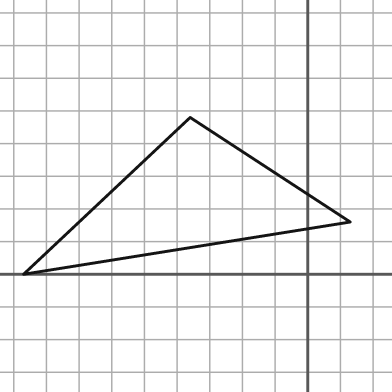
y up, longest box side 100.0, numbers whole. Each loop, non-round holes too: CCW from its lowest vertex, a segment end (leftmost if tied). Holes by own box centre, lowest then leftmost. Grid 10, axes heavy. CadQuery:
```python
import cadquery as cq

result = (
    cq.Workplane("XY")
    .moveTo(-87.0, 0.0)
    .lineTo(13.0, 16.0)
    .lineTo(-36.0, 48.0)
    .close()
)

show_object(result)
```